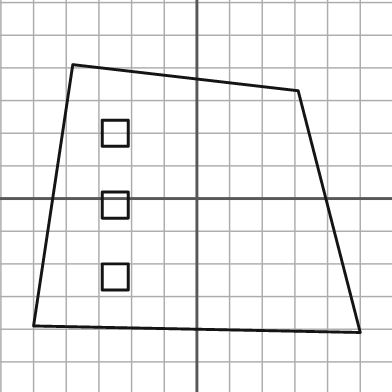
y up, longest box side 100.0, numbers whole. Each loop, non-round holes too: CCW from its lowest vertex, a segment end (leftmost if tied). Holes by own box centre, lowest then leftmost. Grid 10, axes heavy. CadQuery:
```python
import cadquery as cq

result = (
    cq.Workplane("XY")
    .moveTo(50.0, -41.0)
    .lineTo(31.0, 33.0)
    .lineTo(-38.0, 41.0)
    .lineTo(-50.0, -39.0)
    .close()
    .moveTo(-29.0, -28.0)
    .lineTo(-21.0, -28.0)
    .lineTo(-21.0, -20.0)
    .lineTo(-29.0, -20.0)
    .close()
    .moveTo(-29.0, -6.0)
    .lineTo(-21.0, -6.0)
    .lineTo(-21.0, 2.0)
    .lineTo(-29.0, 2.0)
    .close()
    .moveTo(-29.0, 16.0)
    .lineTo(-21.0, 16.0)
    .lineTo(-21.0, 24.0)
    .lineTo(-29.0, 24.0)
    .close()
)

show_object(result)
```